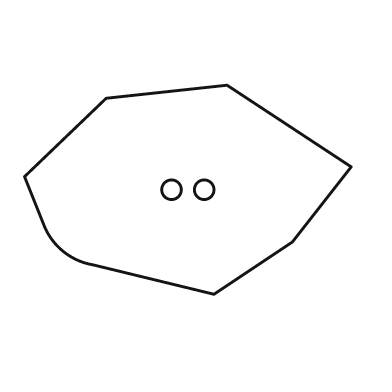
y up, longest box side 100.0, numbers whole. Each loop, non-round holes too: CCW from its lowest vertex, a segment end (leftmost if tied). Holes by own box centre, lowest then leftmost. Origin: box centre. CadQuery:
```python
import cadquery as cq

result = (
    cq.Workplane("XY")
    .moveTo(8.0, -32.0)
    .lineTo(32.0, -16.0)
    .lineTo(50.0, 7.0)
    .lineTo(12.0, 32.0)
    .lineTo(-25.0, 28.0)
    .lineTo(-50.0, 4.0)
    .lineTo(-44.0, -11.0)
    .threePointArc((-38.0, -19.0), (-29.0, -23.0))
    .close()
    .moveTo(-5.0, 0.0)
    .circle(3.0)
    .moveTo(5.0, 0.0)
    .circle(3.0)
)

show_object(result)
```